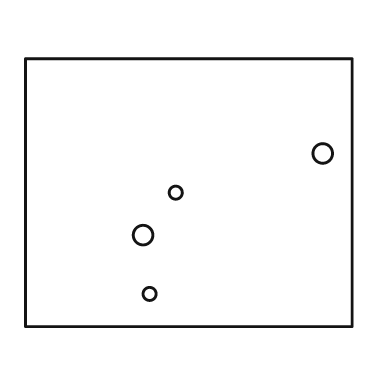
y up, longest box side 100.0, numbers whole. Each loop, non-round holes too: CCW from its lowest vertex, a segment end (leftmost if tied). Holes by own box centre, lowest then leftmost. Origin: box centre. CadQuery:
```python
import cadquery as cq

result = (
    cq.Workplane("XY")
    .moveTo(-50.0, -41.0)
    .lineTo(50.0, -41.0)
    .lineTo(50.0, 41.0)
    .lineTo(-50.0, 41.0)
    .close()
    .moveTo(-12.0, -31.0)
    .circle(2.0)
    .moveTo(-14.0, -13.0)
    .circle(3.0)
    .moveTo(-4.0, 0.0)
    .circle(2.0)
    .moveTo(41.0, 12.0)
    .circle(3.0)
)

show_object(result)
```